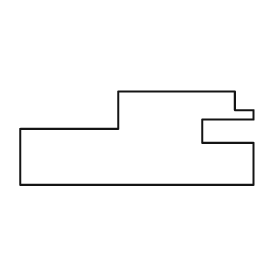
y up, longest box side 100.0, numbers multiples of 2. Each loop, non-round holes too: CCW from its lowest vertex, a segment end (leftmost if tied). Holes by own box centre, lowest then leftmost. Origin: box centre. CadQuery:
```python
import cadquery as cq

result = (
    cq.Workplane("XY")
    .moveTo(-50.0, -20.0)
    .lineTo(50.0, -20.0)
    .lineTo(50.0, -2.0)
    .lineTo(28.0, -2.0)
    .lineTo(28.0, 8.0)
    .lineTo(50.0, 8.0)
    .lineTo(50.0, 12.0)
    .lineTo(42.0, 12.0)
    .lineTo(42.0, 20.0)
    .lineTo(-8.0, 20.0)
    .lineTo(-8.0, 4.0)
    .lineTo(-50.0, 4.0)
    .close()
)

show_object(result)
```